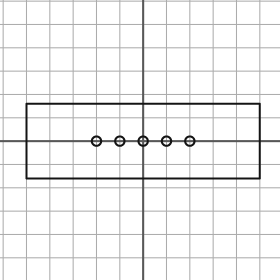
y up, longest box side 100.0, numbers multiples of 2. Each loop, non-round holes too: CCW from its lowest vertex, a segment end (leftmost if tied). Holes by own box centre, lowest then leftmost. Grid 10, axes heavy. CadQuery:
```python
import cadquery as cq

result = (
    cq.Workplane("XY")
    .moveTo(-50.0, -16.0)
    .lineTo(50.0, -16.0)
    .lineTo(50.0, 16.0)
    .lineTo(-50.0, 16.0)
    .close()
    .moveTo(-20.0, 0.0)
    .circle(2.0)
    .moveTo(-10.0, 0.0)
    .circle(2.0)
    .moveTo(0.0, 0.0)
    .circle(2.0)
    .moveTo(10.0, 0.0)
    .circle(2.0)
    .moveTo(20.0, 0.0)
    .circle(2.0)
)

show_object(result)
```